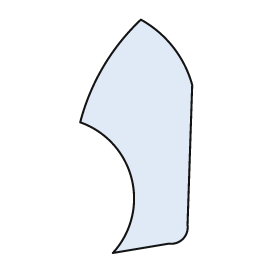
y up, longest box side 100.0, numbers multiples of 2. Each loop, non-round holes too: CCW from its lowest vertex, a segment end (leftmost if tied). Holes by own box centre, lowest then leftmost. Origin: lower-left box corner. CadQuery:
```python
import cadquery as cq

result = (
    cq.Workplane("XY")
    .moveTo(14.0, 0.0)
    .lineTo(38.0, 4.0)
    .threePointArc((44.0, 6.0), (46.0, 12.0))
    .lineTo(48.0, 72.0)
    .threePointArc((40.0, 88.0), (26.0, 100.0))
    .threePointArc((10.0, 80.0), (0.0, 56.0))
    .threePointArc((22.0, 32.0), (14.0, 0.0))
    .close()
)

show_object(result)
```